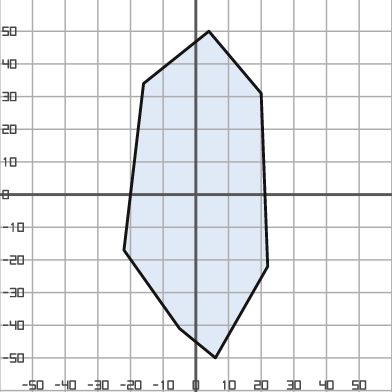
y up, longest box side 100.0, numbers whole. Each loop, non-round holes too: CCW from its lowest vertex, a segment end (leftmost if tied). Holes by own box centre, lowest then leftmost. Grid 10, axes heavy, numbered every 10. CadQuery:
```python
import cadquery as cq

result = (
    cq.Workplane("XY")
    .moveTo(6.0, -50.0)
    .lineTo(22.0, -22.0)
    .lineTo(20.0, 31.0)
    .lineTo(4.0, 50.0)
    .lineTo(-16.0, 34.0)
    .lineTo(-22.0, -17.0)
    .lineTo(-5.0, -41.0)
    .close()
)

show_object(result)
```